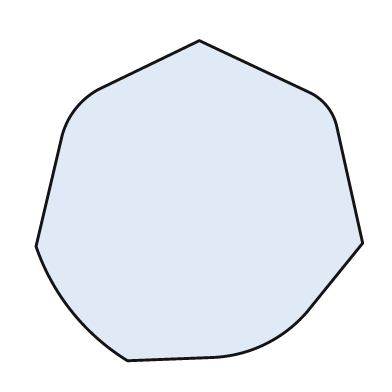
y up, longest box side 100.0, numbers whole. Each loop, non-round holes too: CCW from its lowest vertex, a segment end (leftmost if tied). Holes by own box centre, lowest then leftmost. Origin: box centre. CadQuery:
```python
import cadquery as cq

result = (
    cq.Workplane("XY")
    .moveTo(-22.0, -49.0)
    .lineTo(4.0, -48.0)
    .threePointArc((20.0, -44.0), (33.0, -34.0))
    .lineTo(50.0, -13.0)
    .lineTo(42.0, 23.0)
    .threePointArc((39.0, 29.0), (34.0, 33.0))
    .lineTo(0.0, 49.0)
    .lineTo(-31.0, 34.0)
    .threePointArc((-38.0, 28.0), (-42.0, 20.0))
    .lineTo(-50.0, -14.0)
    .threePointArc((-39.0, -34.0), (-22.0, -49.0))
    .close()
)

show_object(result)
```